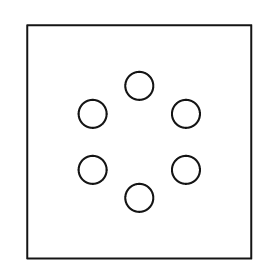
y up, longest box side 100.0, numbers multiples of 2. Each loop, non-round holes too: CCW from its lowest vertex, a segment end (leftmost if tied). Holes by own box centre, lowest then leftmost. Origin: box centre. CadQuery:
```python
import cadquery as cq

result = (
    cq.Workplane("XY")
    .moveTo(-48.0, -50.0)
    .lineTo(48.0, -50.0)
    .lineTo(48.0, 50.0)
    .lineTo(-48.0, 50.0)
    .close()
    .moveTo(0.0, -24.0)
    .circle(6.0)
    .moveTo(-20.0, -12.0)
    .circle(6.0)
    .moveTo(20.0, -12.0)
    .circle(6.0)
    .moveTo(-20.0, 12.0)
    .circle(6.0)
    .moveTo(20.0, 12.0)
    .circle(6.0)
    .moveTo(0.0, 24.0)
    .circle(6.0)
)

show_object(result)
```